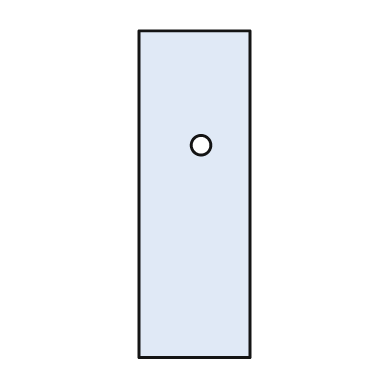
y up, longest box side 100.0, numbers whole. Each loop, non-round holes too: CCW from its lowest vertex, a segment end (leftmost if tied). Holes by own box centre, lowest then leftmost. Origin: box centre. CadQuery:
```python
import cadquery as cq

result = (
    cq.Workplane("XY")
    .moveTo(-17.0, -50.0)
    .lineTo(17.0, -50.0)
    .lineTo(17.0, 50.0)
    .lineTo(-17.0, 50.0)
    .close()
    .moveTo(2.0, 15.0)
    .circle(3.0)
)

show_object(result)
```